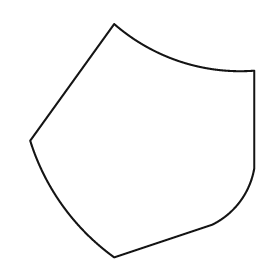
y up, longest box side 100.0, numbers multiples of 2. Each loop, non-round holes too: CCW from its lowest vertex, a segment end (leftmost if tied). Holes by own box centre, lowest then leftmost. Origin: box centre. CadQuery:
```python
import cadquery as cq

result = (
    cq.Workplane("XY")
    .moveTo(-12.0, -50.0)
    .lineTo(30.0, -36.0)
    .threePointArc((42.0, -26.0), (48.0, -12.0))
    .lineTo(48.0, 30.0)
    .threePointArc((16.0, 34.0), (-12.0, 50.0))
    .lineTo(-48.0, 0.0)
    .threePointArc((-34.0, -28.0), (-12.0, -50.0))
    .close()
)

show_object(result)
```